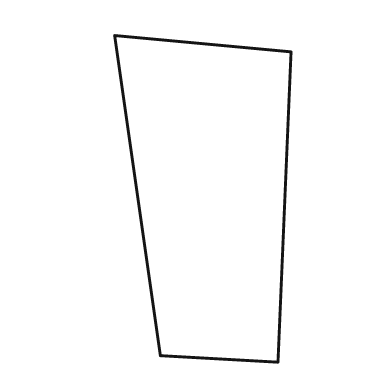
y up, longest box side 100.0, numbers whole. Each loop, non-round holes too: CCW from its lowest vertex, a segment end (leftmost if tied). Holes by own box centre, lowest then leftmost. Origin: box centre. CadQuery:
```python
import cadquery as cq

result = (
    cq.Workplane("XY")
    .moveTo(23.0, -50.0)
    .lineTo(27.0, 45.0)
    .lineTo(-27.0, 50.0)
    .lineTo(-13.0, -48.0)
    .close()
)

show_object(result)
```